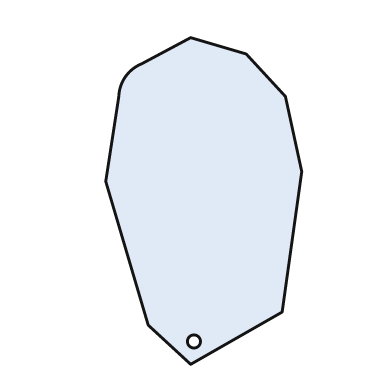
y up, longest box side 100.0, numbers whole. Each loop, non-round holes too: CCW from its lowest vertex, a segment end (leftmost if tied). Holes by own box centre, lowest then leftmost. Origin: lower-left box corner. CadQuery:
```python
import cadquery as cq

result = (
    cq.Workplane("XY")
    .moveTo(26.0, 0.0)
    .lineTo(54.0, 16.0)
    .lineTo(60.0, 59.0)
    .lineTo(55.0, 82.0)
    .lineTo(43.0, 95.0)
    .lineTo(26.0, 100.0)
    .lineTo(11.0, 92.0)
    .threePointArc((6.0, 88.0), (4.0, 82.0))
    .lineTo(0.0, 56.0)
    .lineTo(13.0, 12.0)
    .close()
    .moveTo(27.0, 7.0)
    .circle(2.0)
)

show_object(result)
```